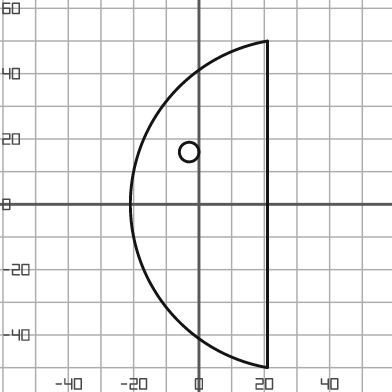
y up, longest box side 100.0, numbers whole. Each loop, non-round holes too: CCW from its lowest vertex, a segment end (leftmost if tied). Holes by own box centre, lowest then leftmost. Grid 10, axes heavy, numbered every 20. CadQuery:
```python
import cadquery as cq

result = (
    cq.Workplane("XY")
    .moveTo(21.0, -50.0)
    .lineTo(21.0, 50.0)
    .threePointArc((-21.0, 0.0), (21.0, -50.0))
    .close()
    .moveTo(-3.0, 16.0)
    .circle(3.0)
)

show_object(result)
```